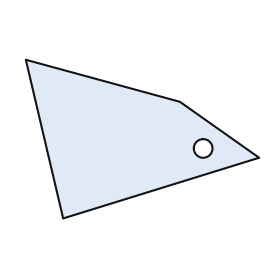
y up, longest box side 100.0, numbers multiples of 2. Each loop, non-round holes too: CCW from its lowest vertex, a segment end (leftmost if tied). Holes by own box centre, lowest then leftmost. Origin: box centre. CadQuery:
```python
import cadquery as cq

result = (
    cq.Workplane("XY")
    .moveTo(-34.0, -34.0)
    .lineTo(50.0, -8.0)
    .lineTo(16.0, 16.0)
    .lineTo(-50.0, 34.0)
    .close()
    .moveTo(26.0, -4.0)
    .circle(4.0)
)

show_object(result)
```